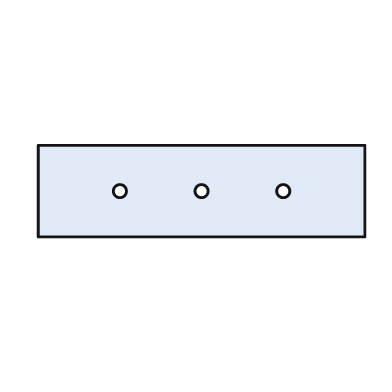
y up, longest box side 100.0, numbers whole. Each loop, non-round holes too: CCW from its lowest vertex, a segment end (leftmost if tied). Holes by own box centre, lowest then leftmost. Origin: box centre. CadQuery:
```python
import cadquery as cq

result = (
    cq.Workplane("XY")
    .moveTo(-50.0, -14.0)
    .lineTo(50.0, -14.0)
    .lineTo(50.0, 14.0)
    .lineTo(-50.0, 14.0)
    .close()
    .moveTo(-25.0, 0.0)
    .circle(2.0)
    .moveTo(0.0, 0.0)
    .circle(2.0)
    .moveTo(25.0, 0.0)
    .circle(2.0)
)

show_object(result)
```